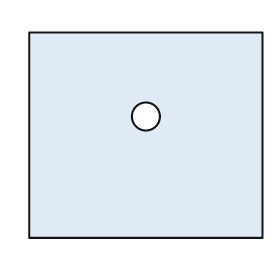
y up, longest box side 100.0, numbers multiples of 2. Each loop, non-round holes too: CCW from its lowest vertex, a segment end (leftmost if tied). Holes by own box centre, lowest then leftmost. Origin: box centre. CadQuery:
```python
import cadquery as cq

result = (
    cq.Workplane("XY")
    .moveTo(-50.0, -44.0)
    .lineTo(50.0, -44.0)
    .lineTo(50.0, 44.0)
    .lineTo(-50.0, 44.0)
    .close()
    .moveTo(0.0, 8.0)
    .circle(6.0)
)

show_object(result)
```